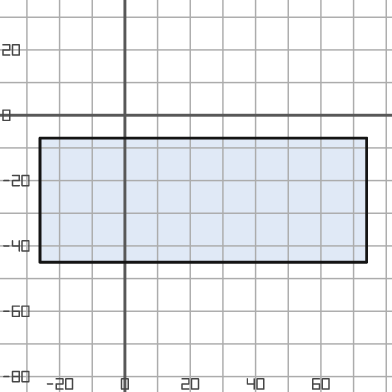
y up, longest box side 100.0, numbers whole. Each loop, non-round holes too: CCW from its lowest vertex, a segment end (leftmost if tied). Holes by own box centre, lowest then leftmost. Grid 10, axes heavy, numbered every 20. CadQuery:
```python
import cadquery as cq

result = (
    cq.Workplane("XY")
    .moveTo(-26.0, -45.0)
    .lineTo(74.0, -45.0)
    .lineTo(74.0, -7.0)
    .lineTo(-26.0, -7.0)
    .close()
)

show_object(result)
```